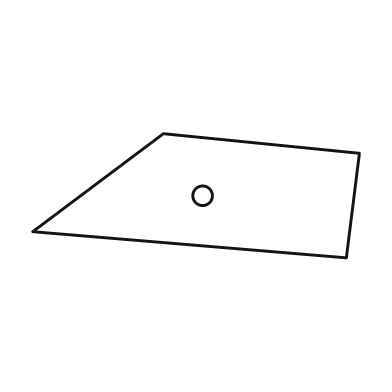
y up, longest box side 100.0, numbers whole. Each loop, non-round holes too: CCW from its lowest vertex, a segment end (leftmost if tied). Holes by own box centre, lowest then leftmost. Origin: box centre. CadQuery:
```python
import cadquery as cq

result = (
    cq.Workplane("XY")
    .moveTo(46.0, -19.0)
    .lineTo(50.0, 13.0)
    .lineTo(-10.0, 19.0)
    .lineTo(-50.0, -11.0)
    .close()
    .moveTo(2.0, 0.0)
    .circle(3.0)
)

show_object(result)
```